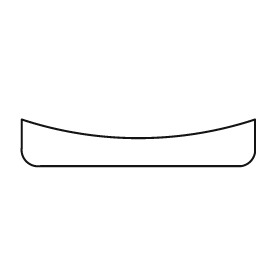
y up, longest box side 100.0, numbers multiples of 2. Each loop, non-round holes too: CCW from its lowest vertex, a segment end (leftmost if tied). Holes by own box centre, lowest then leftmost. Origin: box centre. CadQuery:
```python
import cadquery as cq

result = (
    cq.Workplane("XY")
    .moveTo(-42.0, -10.0)
    .lineTo(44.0, -10.0)
    .threePointArc((48.0, -8.0), (50.0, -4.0))
    .lineTo(50.0, 10.0)
    .threePointArc((0.0, 2.0), (-50.0, 10.0))
    .lineTo(-50.0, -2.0)
    .threePointArc((-48.0, -8.0), (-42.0, -10.0))
    .close()
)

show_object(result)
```